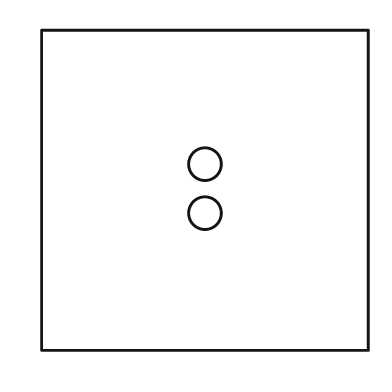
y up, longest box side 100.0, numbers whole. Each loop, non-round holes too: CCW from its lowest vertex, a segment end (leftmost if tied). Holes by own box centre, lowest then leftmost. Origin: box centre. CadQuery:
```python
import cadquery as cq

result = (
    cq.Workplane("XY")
    .moveTo(-50.0, -49.0)
    .lineTo(50.0, -49.0)
    .lineTo(50.0, 49.0)
    .lineTo(-50.0, 49.0)
    .close()
    .moveTo(0.0, -7.0)
    .circle(5.0)
    .moveTo(0.0, 8.0)
    .circle(5.0)
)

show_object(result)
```